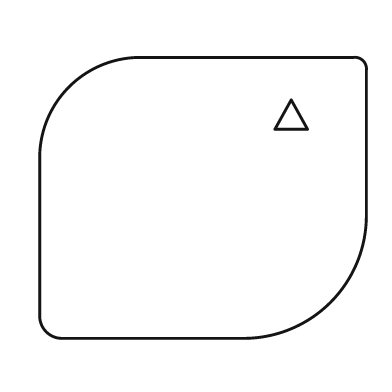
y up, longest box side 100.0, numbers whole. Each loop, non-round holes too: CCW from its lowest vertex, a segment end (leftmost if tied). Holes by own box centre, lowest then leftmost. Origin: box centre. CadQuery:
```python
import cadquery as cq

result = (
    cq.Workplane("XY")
    .moveTo(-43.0, -43.0)
    .lineTo(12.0, -43.0)
    .threePointArc((39.0, -32.0), (50.0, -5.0))
    .lineTo(50.0, 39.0)
    .threePointArc((49.0, 42.0), (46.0, 43.0))
    .lineTo(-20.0, 43.0)
    .threePointArc((-41.0, 34.0), (-50.0, 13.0))
    .lineTo(-50.0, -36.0)
    .threePointArc((-48.0, -41.0), (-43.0, -43.0))
    .close()
    .moveTo(22.0, 21.0)
    .lineTo(32.0, 21.0)
    .lineTo(27.0, 30.0)
    .close()
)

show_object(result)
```